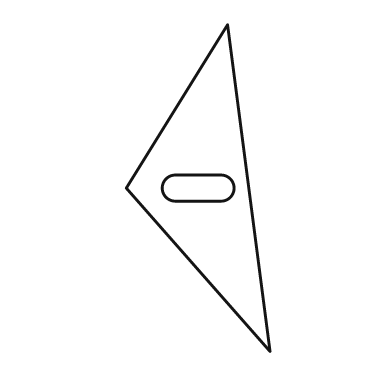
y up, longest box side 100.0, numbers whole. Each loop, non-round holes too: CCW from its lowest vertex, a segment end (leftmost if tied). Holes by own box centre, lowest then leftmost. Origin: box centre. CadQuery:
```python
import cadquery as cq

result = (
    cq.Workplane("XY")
    .moveTo(22.0, -50.0)
    .lineTo(9.0, 50.0)
    .lineTo(-22.0, 0.0)
    .close()
    .moveTo(-7.0, -4.0)
    .lineTo(7.0, -4.0)
    .threePointArc((11.0, 0.0), (7.0, 4.0))
    .lineTo(-7.0, 4.0)
    .threePointArc((-11.0, 0.0), (-7.0, -4.0))
    .close()
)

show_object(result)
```